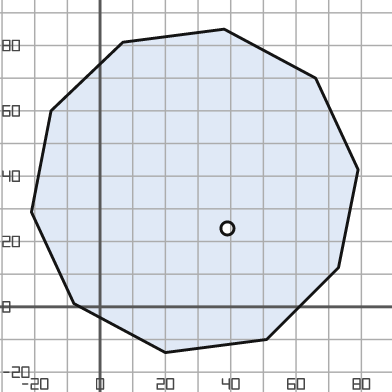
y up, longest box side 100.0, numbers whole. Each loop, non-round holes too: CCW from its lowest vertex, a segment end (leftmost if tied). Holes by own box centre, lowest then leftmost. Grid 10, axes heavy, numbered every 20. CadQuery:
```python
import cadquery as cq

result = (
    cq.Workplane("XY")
    .moveTo(20.0, -14.0)
    .lineTo(51.0, -10.0)
    .lineTo(73.0, 12.0)
    .lineTo(79.0, 42.0)
    .lineTo(66.0, 70.0)
    .lineTo(38.0, 85.0)
    .lineTo(7.0, 81.0)
    .lineTo(-15.0, 60.0)
    .lineTo(-21.0, 29.0)
    .lineTo(-8.0, 1.0)
    .close()
    .moveTo(39.0, 24.0)
    .circle(2.0)
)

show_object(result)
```